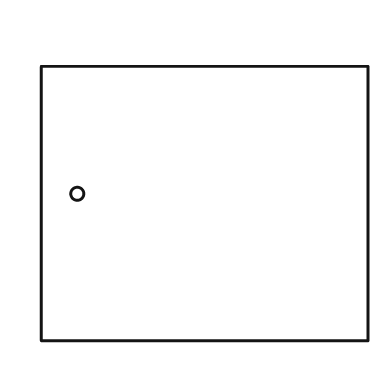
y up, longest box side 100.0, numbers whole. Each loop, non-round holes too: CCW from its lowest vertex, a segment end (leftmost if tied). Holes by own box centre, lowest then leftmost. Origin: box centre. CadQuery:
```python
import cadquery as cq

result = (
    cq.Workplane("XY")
    .moveTo(-50.0, -42.0)
    .lineTo(50.0, -42.0)
    .lineTo(50.0, 42.0)
    .lineTo(-50.0, 42.0)
    .close()
    .moveTo(-39.0, 3.0)
    .circle(2.0)
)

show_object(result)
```